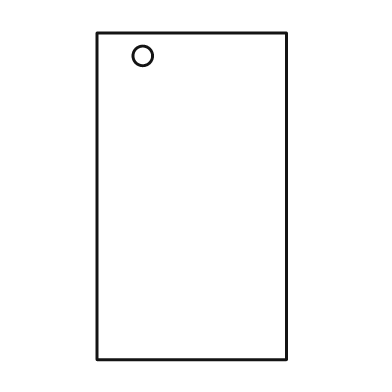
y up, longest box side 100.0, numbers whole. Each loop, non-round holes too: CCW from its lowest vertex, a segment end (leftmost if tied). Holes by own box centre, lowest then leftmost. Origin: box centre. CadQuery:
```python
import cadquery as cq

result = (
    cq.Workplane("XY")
    .moveTo(-29.0, -50.0)
    .lineTo(29.0, -50.0)
    .lineTo(29.0, 50.0)
    .lineTo(-29.0, 50.0)
    .close()
    .moveTo(-15.0, 43.0)
    .circle(3.0)
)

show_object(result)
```